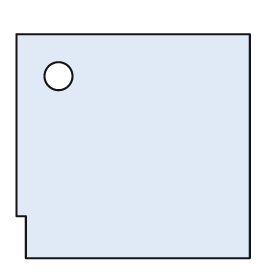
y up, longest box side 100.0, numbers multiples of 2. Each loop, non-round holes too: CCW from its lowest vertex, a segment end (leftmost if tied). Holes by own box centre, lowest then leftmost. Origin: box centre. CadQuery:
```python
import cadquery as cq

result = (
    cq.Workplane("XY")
    .moveTo(-46.0, -48.0)
    .lineTo(50.0, -48.0)
    .lineTo(50.0, 48.0)
    .lineTo(-50.0, 48.0)
    .lineTo(-50.0, -30.0)
    .lineTo(-46.0, -30.0)
    .close()
    .moveTo(-32.0, 30.0)
    .circle(6.0)
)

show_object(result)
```